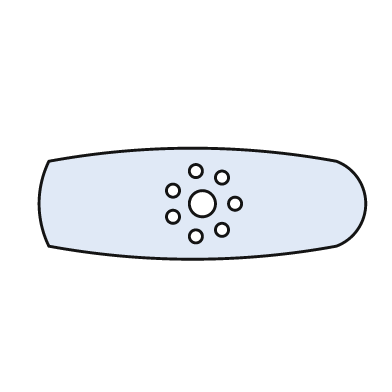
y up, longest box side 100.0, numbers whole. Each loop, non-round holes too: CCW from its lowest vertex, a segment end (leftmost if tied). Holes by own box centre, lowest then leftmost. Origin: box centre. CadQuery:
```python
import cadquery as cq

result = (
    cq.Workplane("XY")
    .moveTo(-47.0, -13.0)
    .threePointArc((-3.0, -17.0), (41.0, -13.0))
    .threePointArc((50.0, 0.0), (41.0, 13.0))
    .threePointArc((-3.0, 17.0), (-47.0, 13.0))
    .threePointArc((-50.0, 0.0), (-47.0, -13.0))
    .close()
    .moveTo(-2.0, -10.0)
    .circle(2.0)
    .moveTo(6.0, -8.0)
    .circle(2.0)
    .moveTo(-9.0, -4.0)
    .circle(2.0)
    .moveTo(0.0, 0.0)
    .circle(4.0)
    .moveTo(10.0, 0.0)
    .circle(2.0)
    .moveTo(-9.0, 4.0)
    .circle(2.0)
    .moveTo(6.0, 8.0)
    .circle(2.0)
    .moveTo(-2.0, 10.0)
    .circle(2.0)
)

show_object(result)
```